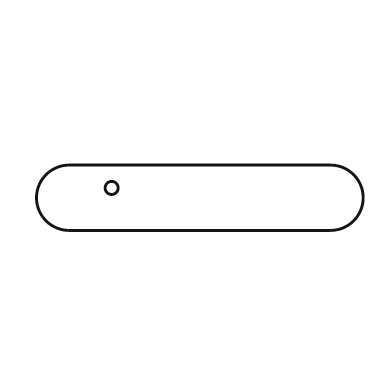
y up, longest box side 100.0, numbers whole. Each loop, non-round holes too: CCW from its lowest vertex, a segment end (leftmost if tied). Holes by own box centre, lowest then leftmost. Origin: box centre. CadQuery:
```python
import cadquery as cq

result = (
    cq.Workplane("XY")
    .moveTo(-40.0, -10.0)
    .lineTo(40.0, -10.0)
    .threePointArc((50.0, 0.0), (40.0, 10.0))
    .lineTo(-40.0, 10.0)
    .threePointArc((-50.0, 0.0), (-40.0, -10.0))
    .close()
    .moveTo(-27.0, 3.0)
    .circle(2.0)
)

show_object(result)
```